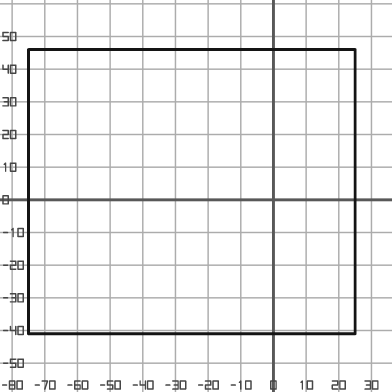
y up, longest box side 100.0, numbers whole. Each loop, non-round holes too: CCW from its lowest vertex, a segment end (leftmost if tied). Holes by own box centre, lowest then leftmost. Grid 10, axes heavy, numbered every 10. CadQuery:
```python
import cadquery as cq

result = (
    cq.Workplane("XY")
    .moveTo(-75.0, -41.0)
    .lineTo(25.0, -41.0)
    .lineTo(25.0, 46.0)
    .lineTo(-75.0, 46.0)
    .close()
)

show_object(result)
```